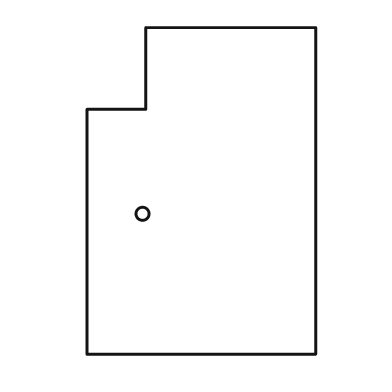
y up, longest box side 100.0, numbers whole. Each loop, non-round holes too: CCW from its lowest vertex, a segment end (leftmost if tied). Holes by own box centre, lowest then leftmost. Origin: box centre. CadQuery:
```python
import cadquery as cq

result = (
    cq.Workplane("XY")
    .moveTo(-35.0, -50.0)
    .lineTo(35.0, -50.0)
    .lineTo(35.0, 50.0)
    .lineTo(-17.0, 50.0)
    .lineTo(-17.0, 25.0)
    .lineTo(-35.0, 25.0)
    .close()
    .moveTo(-18.0, -7.0)
    .circle(2.0)
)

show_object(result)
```